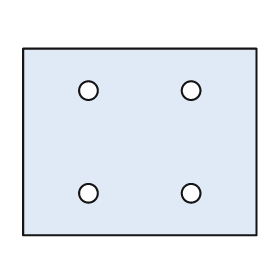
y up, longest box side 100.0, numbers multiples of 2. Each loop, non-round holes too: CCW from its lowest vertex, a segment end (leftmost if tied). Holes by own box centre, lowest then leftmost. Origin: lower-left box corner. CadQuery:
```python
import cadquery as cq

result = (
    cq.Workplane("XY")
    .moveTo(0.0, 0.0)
    .lineTo(100.0, 0.0)
    .lineTo(100.0, 80.0)
    .lineTo(0.0, 80.0)
    .close()
    .moveTo(28.0, 18.0)
    .circle(4.0)
    .moveTo(72.0, 18.0)
    .circle(4.0)
    .moveTo(28.0, 62.0)
    .circle(4.0)
    .moveTo(72.0, 62.0)
    .circle(4.0)
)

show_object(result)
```